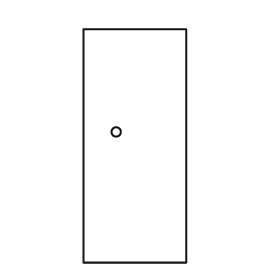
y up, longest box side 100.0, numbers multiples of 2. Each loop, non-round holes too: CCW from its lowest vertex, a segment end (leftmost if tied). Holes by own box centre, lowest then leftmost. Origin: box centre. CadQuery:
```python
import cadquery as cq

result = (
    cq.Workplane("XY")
    .moveTo(-22.0, -50.0)
    .lineTo(22.0, -50.0)
    .lineTo(22.0, 50.0)
    .lineTo(-22.0, 50.0)
    .close()
    .moveTo(-8.0, 6.0)
    .circle(2.0)
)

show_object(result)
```